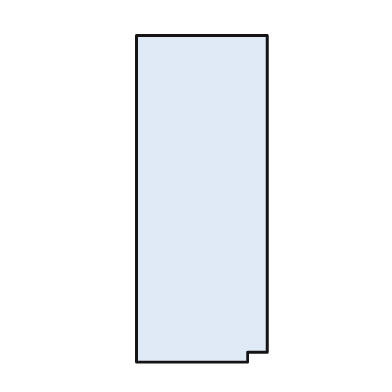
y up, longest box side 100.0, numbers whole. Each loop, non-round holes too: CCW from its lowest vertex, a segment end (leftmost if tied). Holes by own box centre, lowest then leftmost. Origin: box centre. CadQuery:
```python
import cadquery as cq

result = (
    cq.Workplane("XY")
    .moveTo(-20.0, -50.0)
    .lineTo(14.0, -50.0)
    .lineTo(14.0, -47.0)
    .lineTo(20.0, -47.0)
    .lineTo(20.0, 50.0)
    .lineTo(-20.0, 50.0)
    .close()
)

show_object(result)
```